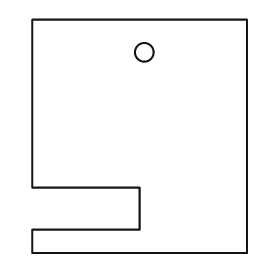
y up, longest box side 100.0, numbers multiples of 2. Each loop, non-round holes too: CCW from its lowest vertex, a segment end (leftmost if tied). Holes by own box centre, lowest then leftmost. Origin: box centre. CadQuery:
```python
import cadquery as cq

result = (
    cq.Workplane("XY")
    .moveTo(-46.0, -50.0)
    .lineTo(46.0, -50.0)
    .lineTo(46.0, 50.0)
    .lineTo(-46.0, 50.0)
    .lineTo(-46.0, -22.0)
    .lineTo(0.0, -22.0)
    .lineTo(0.0, -40.0)
    .lineTo(-46.0, -40.0)
    .close()
    .moveTo(2.0, 36.0)
    .circle(4.0)
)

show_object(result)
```